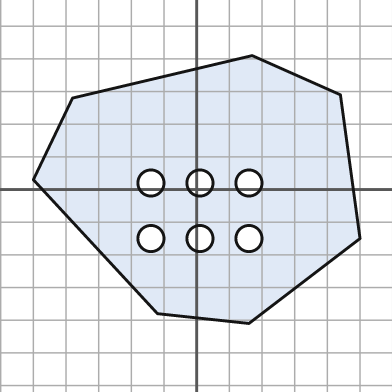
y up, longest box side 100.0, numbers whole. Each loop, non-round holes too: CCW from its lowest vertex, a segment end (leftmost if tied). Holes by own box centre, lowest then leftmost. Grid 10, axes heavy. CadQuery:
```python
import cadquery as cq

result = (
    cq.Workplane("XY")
    .moveTo(16.0, -41.0)
    .lineTo(50.0, -15.0)
    .lineTo(44.0, 29.0)
    .lineTo(17.0, 41.0)
    .lineTo(-38.0, 28.0)
    .lineTo(-50.0, 3.0)
    .lineTo(-12.0, -38.0)
    .close()
    .moveTo(-14.0, -15.0)
    .circle(4.0)
    .moveTo(1.0, -15.0)
    .circle(4.0)
    .moveTo(16.0, -15.0)
    .circle(4.0)
    .moveTo(-14.0, 2.0)
    .circle(4.0)
    .moveTo(1.0, 2.0)
    .circle(4.0)
    .moveTo(16.0, 2.0)
    .circle(4.0)
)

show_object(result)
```